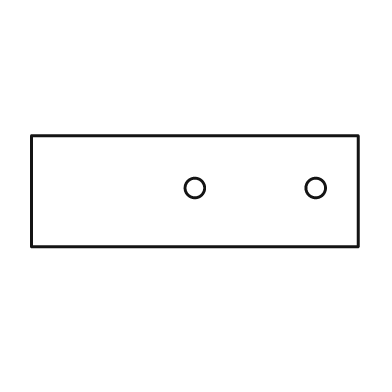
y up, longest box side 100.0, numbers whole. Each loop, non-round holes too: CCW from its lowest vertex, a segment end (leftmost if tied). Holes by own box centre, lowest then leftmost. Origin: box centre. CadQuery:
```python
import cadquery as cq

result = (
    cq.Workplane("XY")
    .moveTo(-50.0, -17.0)
    .lineTo(50.0, -17.0)
    .lineTo(50.0, 17.0)
    .lineTo(-50.0, 17.0)
    .close()
    .moveTo(0.0, 1.0)
    .circle(3.0)
    .moveTo(37.0, 1.0)
    .circle(3.0)
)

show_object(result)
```